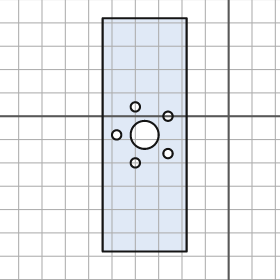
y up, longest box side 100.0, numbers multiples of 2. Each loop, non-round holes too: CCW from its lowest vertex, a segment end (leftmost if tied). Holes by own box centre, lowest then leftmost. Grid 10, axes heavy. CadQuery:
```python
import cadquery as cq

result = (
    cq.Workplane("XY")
    .moveTo(-54.0, -58.0)
    .lineTo(-18.0, -58.0)
    .lineTo(-18.0, 42.0)
    .lineTo(-54.0, 42.0)
    .close()
    .moveTo(-40.0, -20.0)
    .circle(2.0)
    .moveTo(-26.0, -16.0)
    .circle(2.0)
    .moveTo(-48.0, -8.0)
    .circle(2.0)
    .moveTo(-36.0, -8.0)
    .circle(6.0)
    .moveTo(-26.0, 0.0)
    .circle(2.0)
    .moveTo(-40.0, 4.0)
    .circle(2.0)
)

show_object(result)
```